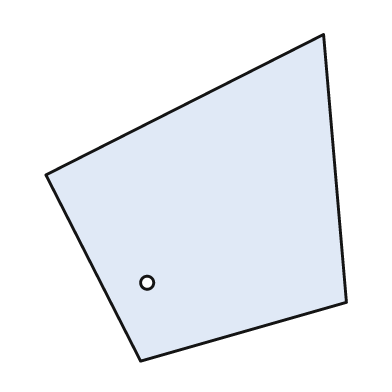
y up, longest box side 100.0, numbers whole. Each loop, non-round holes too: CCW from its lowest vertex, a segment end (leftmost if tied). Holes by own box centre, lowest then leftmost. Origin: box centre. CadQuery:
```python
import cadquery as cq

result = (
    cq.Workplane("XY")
    .moveTo(-17.0, -50.0)
    .lineTo(46.0, -32.0)
    .lineTo(39.0, 50.0)
    .lineTo(-46.0, 7.0)
    .close()
    .moveTo(-15.0, -26.0)
    .circle(2.0)
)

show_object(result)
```